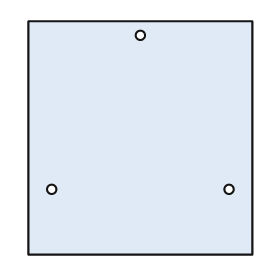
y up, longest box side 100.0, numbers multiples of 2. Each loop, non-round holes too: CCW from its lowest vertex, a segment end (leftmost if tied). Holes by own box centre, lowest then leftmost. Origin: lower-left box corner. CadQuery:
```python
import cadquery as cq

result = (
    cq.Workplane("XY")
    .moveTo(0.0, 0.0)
    .lineTo(96.0, 0.0)
    .lineTo(96.0, 100.0)
    .lineTo(0.0, 100.0)
    .close()
    .moveTo(10.0, 28.0)
    .circle(2.0)
    .moveTo(86.0, 28.0)
    .circle(2.0)
    .moveTo(48.0, 94.0)
    .circle(2.0)
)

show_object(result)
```